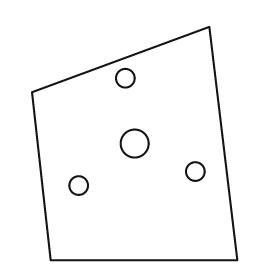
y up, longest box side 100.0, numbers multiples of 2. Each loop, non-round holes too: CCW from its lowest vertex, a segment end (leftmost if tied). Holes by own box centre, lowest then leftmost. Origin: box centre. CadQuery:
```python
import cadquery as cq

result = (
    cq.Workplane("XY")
    .moveTo(-36.0, -50.0)
    .lineTo(44.0, -50.0)
    .lineTo(32.0, 50.0)
    .lineTo(-44.0, 22.0)
    .close()
    .moveTo(-24.0, -18.0)
    .circle(4.0)
    .moveTo(26.0, -12.0)
    .circle(4.0)
    .moveTo(0.0, 0.0)
    .circle(6.0)
    .moveTo(-4.0, 28.0)
    .circle(4.0)
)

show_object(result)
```